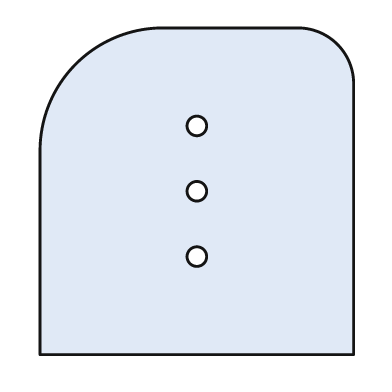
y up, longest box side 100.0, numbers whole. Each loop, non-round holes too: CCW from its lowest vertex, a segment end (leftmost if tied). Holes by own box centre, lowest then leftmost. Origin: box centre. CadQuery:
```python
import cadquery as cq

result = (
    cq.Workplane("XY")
    .moveTo(-48.0, -50.0)
    .lineTo(48.0, -50.0)
    .lineTo(48.0, 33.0)
    .threePointArc((43.0, 45.0), (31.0, 50.0))
    .lineTo(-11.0, 50.0)
    .threePointArc((-37.0, 39.0), (-48.0, 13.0))
    .close()
    .moveTo(0.0, -20.0)
    .circle(3.0)
    .moveTo(0.0, 0.0)
    .circle(3.0)
    .moveTo(0.0, 20.0)
    .circle(3.0)
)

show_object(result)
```